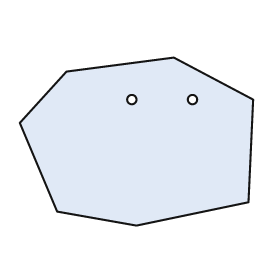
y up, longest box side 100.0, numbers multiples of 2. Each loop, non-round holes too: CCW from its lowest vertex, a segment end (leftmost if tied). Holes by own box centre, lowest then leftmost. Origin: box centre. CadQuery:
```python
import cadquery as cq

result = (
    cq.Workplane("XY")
    .moveTo(0.0, -36.0)
    .lineTo(48.0, -26.0)
    .lineTo(50.0, 18.0)
    .lineTo(16.0, 36.0)
    .lineTo(-30.0, 30.0)
    .lineTo(-50.0, 8.0)
    .lineTo(-34.0, -30.0)
    .close()
    .moveTo(-2.0, 18.0)
    .circle(2.0)
    .moveTo(24.0, 18.0)
    .circle(2.0)
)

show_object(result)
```